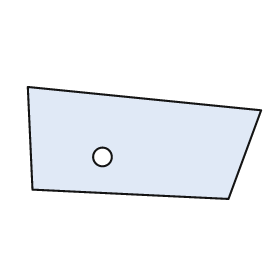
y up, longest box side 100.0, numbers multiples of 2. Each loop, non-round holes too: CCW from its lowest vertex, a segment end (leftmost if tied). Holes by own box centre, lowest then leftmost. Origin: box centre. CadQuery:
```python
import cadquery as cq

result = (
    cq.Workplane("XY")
    .moveTo(36.0, -24.0)
    .lineTo(50.0, 14.0)
    .lineTo(-50.0, 24.0)
    .lineTo(-48.0, -20.0)
    .close()
    .moveTo(-18.0, -6.0)
    .circle(4.0)
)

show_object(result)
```